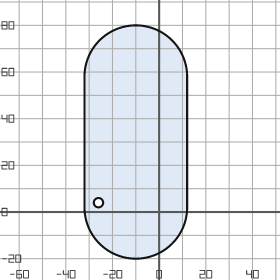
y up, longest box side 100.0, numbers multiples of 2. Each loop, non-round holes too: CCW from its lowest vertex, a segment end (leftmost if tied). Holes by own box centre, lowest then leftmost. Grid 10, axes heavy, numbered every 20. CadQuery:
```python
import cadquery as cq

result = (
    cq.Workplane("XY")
    .moveTo(-32.0, 2.0)
    .threePointArc((-10.0, -20.0), (12.0, 2.0))
    .lineTo(12.0, 58.0)
    .threePointArc((-10.0, 80.0), (-32.0, 58.0))
    .close()
    .moveTo(-26.0, 4.0)
    .circle(2.0)
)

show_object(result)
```